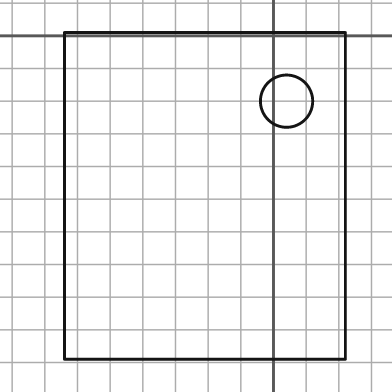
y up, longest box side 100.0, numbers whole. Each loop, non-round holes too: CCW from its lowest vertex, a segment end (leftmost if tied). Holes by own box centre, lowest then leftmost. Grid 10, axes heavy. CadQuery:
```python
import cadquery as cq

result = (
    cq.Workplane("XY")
    .moveTo(-64.0, -99.0)
    .lineTo(22.0, -99.0)
    .lineTo(22.0, 1.0)
    .lineTo(-64.0, 1.0)
    .close()
    .moveTo(4.0, -20.0)
    .circle(8.0)
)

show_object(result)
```